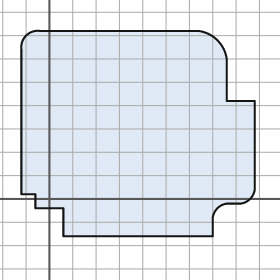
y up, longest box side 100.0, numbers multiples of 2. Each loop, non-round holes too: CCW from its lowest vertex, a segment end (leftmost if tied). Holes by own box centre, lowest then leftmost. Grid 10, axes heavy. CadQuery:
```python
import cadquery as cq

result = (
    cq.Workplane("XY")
    .moveTo(6.0, -16.0)
    .lineTo(70.0, -16.0)
    .lineTo(70.0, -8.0)
    .threePointArc((72.0, -4.0), (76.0, -2.0))
    .lineTo(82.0, -2.0)
    .threePointArc((86.0, 0.0), (88.0, 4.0))
    .lineTo(88.0, 42.0)
    .lineTo(76.0, 42.0)
    .lineTo(76.0, 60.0)
    .threePointArc((72.0, 68.0), (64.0, 72.0))
    .lineTo(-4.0, 72.0)
    .threePointArc((-10.0, 70.0), (-12.0, 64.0))
    .lineTo(-12.0, 2.0)
    .lineTo(-6.0, 2.0)
    .lineTo(-6.0, -4.0)
    .lineTo(6.0, -4.0)
    .close()
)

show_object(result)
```